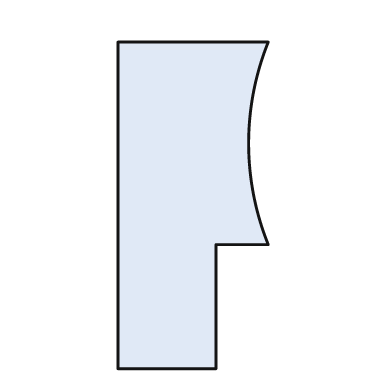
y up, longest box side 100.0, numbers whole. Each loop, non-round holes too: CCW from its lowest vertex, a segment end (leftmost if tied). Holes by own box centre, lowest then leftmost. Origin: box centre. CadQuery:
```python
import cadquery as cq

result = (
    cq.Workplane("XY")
    .moveTo(-23.0, -50.0)
    .lineTo(7.0, -50.0)
    .lineTo(7.0, -12.0)
    .lineTo(23.0, -12.0)
    .threePointArc((17.0, 19.0), (23.0, 50.0))
    .lineTo(-23.0, 50.0)
    .close()
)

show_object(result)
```